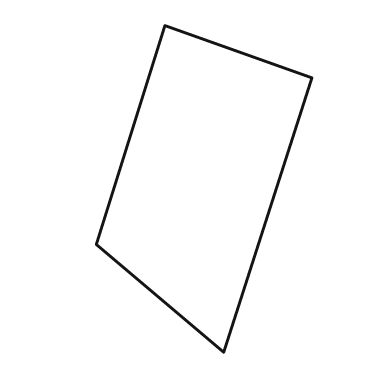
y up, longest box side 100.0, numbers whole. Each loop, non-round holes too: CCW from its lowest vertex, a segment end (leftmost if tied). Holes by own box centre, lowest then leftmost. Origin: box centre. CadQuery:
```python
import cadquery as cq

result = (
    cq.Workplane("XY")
    .moveTo(6.0, -50.0)
    .lineTo(33.0, 34.0)
    .lineTo(-12.0, 50.0)
    .lineTo(-33.0, -17.0)
    .close()
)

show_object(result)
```